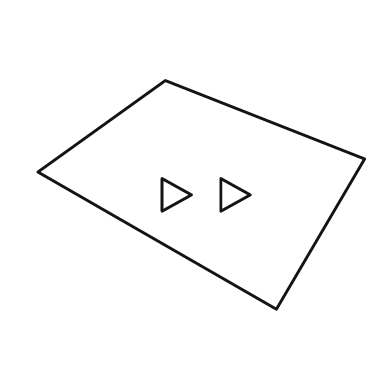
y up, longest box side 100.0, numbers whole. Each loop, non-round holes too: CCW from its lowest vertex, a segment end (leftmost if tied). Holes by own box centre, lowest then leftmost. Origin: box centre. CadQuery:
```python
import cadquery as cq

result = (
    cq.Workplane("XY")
    .moveTo(23.0, -35.0)
    .lineTo(50.0, 11.0)
    .lineTo(-11.0, 35.0)
    .lineTo(-50.0, 7.0)
    .close()
    .moveTo(-12.0, -5.0)
    .lineTo(-3.0, 0.0)
    .lineTo(-12.0, 5.0)
    .close()
    .moveTo(6.0, -5.0)
    .lineTo(15.0, 0.0)
    .lineTo(6.0, 5.0)
    .close()
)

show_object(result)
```